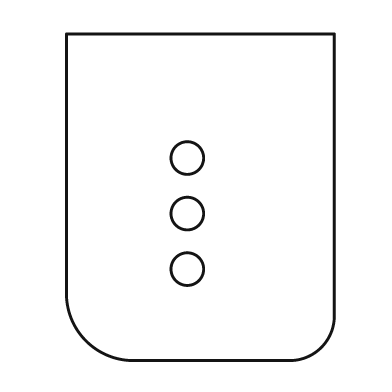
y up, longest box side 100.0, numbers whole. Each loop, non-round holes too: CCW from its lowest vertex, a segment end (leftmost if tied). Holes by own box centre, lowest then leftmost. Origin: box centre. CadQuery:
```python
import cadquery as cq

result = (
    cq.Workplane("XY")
    .moveTo(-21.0, -50.0)
    .lineTo(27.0, -50.0)
    .threePointArc((37.0, -46.0), (41.0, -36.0))
    .lineTo(41.0, 50.0)
    .lineTo(-41.0, 50.0)
    .lineTo(-41.0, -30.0)
    .threePointArc((-35.0, -44.0), (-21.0, -50.0))
    .close()
    .moveTo(-4.0, -22.0)
    .circle(5.0)
    .moveTo(-4.0, -5.0)
    .circle(5.0)
    .moveTo(-4.0, 12.0)
    .circle(5.0)
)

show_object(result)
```